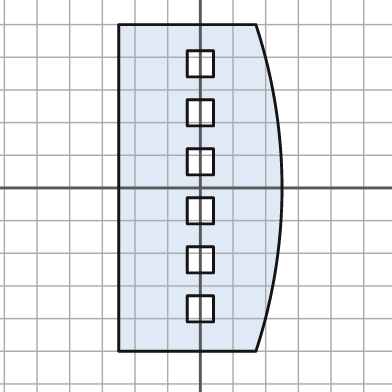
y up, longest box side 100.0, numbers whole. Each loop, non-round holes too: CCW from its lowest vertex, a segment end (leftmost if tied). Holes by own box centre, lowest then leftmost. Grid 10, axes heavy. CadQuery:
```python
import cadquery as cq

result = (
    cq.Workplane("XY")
    .moveTo(-25.0, -50.0)
    .lineTo(17.0, -50.0)
    .threePointArc((25.0, 0.0), (17.0, 50.0))
    .lineTo(-25.0, 50.0)
    .close()
    .moveTo(-4.0, -41.0)
    .lineTo(4.0, -41.0)
    .lineTo(4.0, -33.0)
    .lineTo(-4.0, -33.0)
    .close()
    .moveTo(-4.0, -26.0)
    .lineTo(4.0, -26.0)
    .lineTo(4.0, -18.0)
    .lineTo(-4.0, -18.0)
    .close()
    .moveTo(-4.0, -11.0)
    .lineTo(4.0, -11.0)
    .lineTo(4.0, -3.0)
    .lineTo(-4.0, -3.0)
    .close()
    .moveTo(-4.0, 4.0)
    .lineTo(4.0, 4.0)
    .lineTo(4.0, 12.0)
    .lineTo(-4.0, 12.0)
    .close()
    .moveTo(-4.0, 19.0)
    .lineTo(4.0, 19.0)
    .lineTo(4.0, 27.0)
    .lineTo(-4.0, 27.0)
    .close()
    .moveTo(-4.0, 34.0)
    .lineTo(4.0, 34.0)
    .lineTo(4.0, 42.0)
    .lineTo(-4.0, 42.0)
    .close()
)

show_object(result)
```